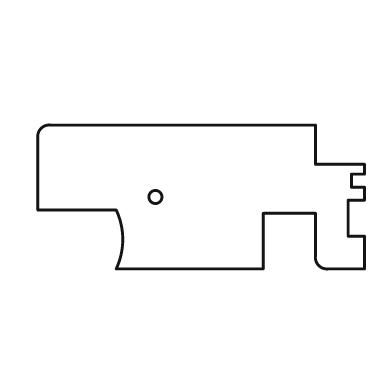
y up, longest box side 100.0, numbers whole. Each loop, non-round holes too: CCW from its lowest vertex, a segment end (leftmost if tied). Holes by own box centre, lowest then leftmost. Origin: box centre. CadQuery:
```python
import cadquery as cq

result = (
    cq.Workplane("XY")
    .moveTo(-26.0, -22.0)
    .lineTo(19.0, -22.0)
    .lineTo(19.0, -5.0)
    .lineTo(35.0, -5.0)
    .lineTo(35.0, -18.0)
    .threePointArc((36.0, -21.0), (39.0, -22.0))
    .lineTo(50.0, -22.0)
    .lineTo(50.0, -12.0)
    .lineTo(45.0, -12.0)
    .lineTo(45.0, -1.0)
    .lineTo(50.0, -1.0)
    .lineTo(50.0, 3.0)
    .lineTo(46.0, 3.0)
    .lineTo(46.0, 7.0)
    .lineTo(50.0, 7.0)
    .lineTo(50.0, 10.0)
    .lineTo(35.0, 10.0)
    .lineTo(35.0, 22.0)
    .lineTo(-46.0, 22.0)
    .threePointArc((-49.0, 21.0), (-50.0, 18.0))
    .lineTo(-50.0, -4.0)
    .lineTo(-26.0, -4.0)
    .threePointArc((-24.0, -13.0), (-26.0, -22.0))
    .close()
    .moveTo(-14.0, 0.0)
    .circle(2.0)
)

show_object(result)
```